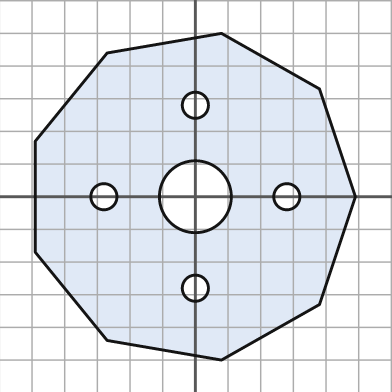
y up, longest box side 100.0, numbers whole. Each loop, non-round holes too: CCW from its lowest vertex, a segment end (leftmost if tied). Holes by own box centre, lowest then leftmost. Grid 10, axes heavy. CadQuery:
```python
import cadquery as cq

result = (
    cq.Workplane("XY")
    .moveTo(8.0, -50.0)
    .lineTo(38.0, -33.0)
    .lineTo(49.0, 0.0)
    .lineTo(38.0, 33.0)
    .lineTo(8.0, 50.0)
    .lineTo(-27.0, 44.0)
    .lineTo(-49.0, 17.0)
    .lineTo(-49.0, -17.0)
    .lineTo(-27.0, -44.0)
    .close()
    .moveTo(0.0, -28.0)
    .circle(4.0)
    .moveTo(-28.0, 0.0)
    .circle(4.0)
    .moveTo(0.0, 0.0)
    .circle(11.0)
    .moveTo(28.0, 0.0)
    .circle(4.0)
    .moveTo(0.0, 28.0)
    .circle(4.0)
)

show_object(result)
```